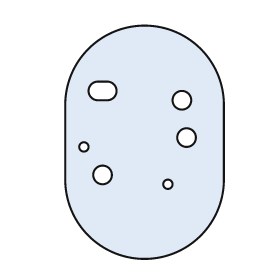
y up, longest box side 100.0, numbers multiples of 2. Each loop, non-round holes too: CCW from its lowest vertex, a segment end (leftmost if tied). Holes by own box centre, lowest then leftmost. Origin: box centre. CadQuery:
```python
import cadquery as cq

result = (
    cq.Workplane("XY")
    .moveTo(-34.0, -16.0)
    .threePointArc((0.0, -50.0), (34.0, -16.0))
    .lineTo(34.0, 16.0)
    .threePointArc((0.0, 50.0), (-34.0, 16.0))
    .close()
    .moveTo(10.0, -18.0)
    .circle(2.0)
    .moveTo(-18.0, -14.0)
    .circle(4.0)
    .moveTo(-26.0, -2.0)
    .circle(2.0)
    .moveTo(18.0, 2.0)
    .circle(4.0)
    .moveTo(16.0, 18.0)
    .circle(4.0)
    .moveTo(-20.0, 18.0)
    .lineTo(-16.0, 18.0)
    .threePointArc((-12.0, 22.0), (-16.0, 26.0))
    .lineTo(-20.0, 26.0)
    .threePointArc((-24.0, 22.0), (-20.0, 18.0))
    .close()
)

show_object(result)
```